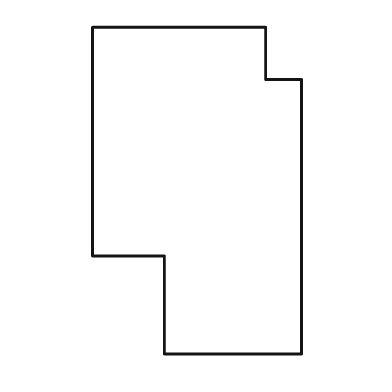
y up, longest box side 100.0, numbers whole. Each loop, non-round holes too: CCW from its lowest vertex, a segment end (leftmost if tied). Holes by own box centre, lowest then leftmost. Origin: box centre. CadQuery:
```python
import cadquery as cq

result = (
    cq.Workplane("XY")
    .moveTo(-10.0, -50.0)
    .lineTo(32.0, -50.0)
    .lineTo(32.0, 34.0)
    .lineTo(21.0, 34.0)
    .lineTo(21.0, 50.0)
    .lineTo(-32.0, 50.0)
    .lineTo(-32.0, -20.0)
    .lineTo(-10.0, -20.0)
    .close()
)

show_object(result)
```